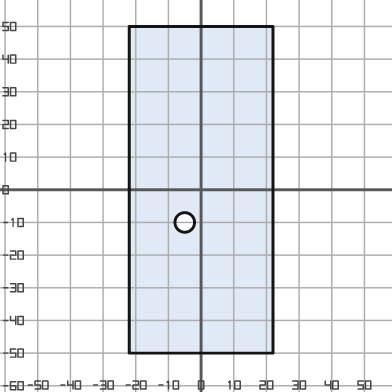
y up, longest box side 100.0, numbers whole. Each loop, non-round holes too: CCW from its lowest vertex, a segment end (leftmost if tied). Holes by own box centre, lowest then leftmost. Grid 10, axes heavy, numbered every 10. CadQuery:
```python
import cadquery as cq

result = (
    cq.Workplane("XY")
    .moveTo(-22.0, -50.0)
    .lineTo(22.0, -50.0)
    .lineTo(22.0, 50.0)
    .lineTo(-22.0, 50.0)
    .close()
    .moveTo(-5.0, -10.0)
    .circle(3.0)
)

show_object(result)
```